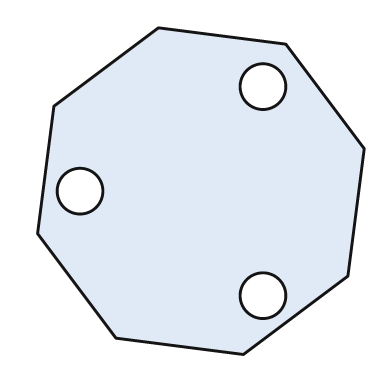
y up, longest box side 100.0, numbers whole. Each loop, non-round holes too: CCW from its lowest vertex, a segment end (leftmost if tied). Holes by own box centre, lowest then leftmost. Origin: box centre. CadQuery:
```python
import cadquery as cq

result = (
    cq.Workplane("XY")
    .moveTo(13.0, -50.0)
    .lineTo(45.0, -26.0)
    .lineTo(50.0, 13.0)
    .lineTo(26.0, 45.0)
    .lineTo(-13.0, 50.0)
    .lineTo(-45.0, 26.0)
    .lineTo(-50.0, -13.0)
    .lineTo(-26.0, -45.0)
    .close()
    .moveTo(19.0, -32.0)
    .circle(7.0)
    .moveTo(-37.0, 0.0)
    .circle(7.0)
    .moveTo(19.0, 32.0)
    .circle(7.0)
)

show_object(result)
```